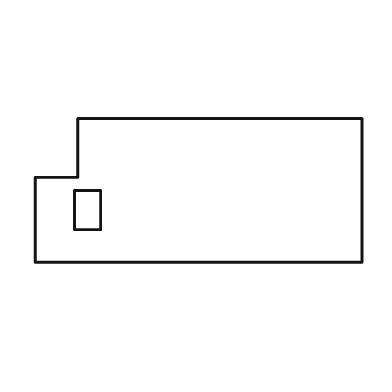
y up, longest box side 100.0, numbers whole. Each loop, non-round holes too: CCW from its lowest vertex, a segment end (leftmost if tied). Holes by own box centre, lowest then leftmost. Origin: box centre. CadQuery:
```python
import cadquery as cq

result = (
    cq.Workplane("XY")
    .moveTo(-50.0, -22.0)
    .lineTo(50.0, -22.0)
    .lineTo(50.0, 22.0)
    .lineTo(-37.0, 22.0)
    .lineTo(-37.0, 4.0)
    .lineTo(-50.0, 4.0)
    .close()
    .moveTo(-38.0, -12.0)
    .lineTo(-30.0, -12.0)
    .lineTo(-30.0, 0.0)
    .lineTo(-38.0, 0.0)
    .close()
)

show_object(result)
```